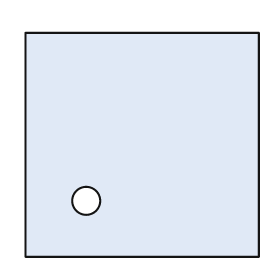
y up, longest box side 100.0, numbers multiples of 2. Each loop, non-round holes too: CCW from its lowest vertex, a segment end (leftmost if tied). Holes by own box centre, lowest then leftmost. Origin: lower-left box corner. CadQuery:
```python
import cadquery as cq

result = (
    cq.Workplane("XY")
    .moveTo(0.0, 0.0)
    .lineTo(100.0, 0.0)
    .lineTo(100.0, 96.0)
    .lineTo(0.0, 96.0)
    .close()
    .moveTo(26.0, 24.0)
    .circle(6.0)
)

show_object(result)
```